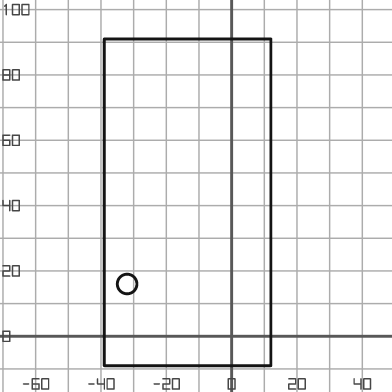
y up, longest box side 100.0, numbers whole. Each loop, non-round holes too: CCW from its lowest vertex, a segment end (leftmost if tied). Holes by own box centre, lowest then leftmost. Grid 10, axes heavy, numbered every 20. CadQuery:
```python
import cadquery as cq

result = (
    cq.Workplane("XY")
    .moveTo(-39.0, -9.0)
    .lineTo(12.0, -9.0)
    .lineTo(12.0, 91.0)
    .lineTo(-39.0, 91.0)
    .close()
    .moveTo(-32.0, 16.0)
    .circle(3.0)
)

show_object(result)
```